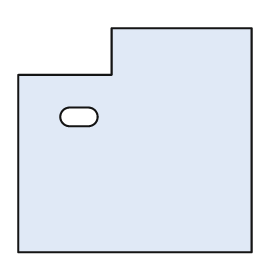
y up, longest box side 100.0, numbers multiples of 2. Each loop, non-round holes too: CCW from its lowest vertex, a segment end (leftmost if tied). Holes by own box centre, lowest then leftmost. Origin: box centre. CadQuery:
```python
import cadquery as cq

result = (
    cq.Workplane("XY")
    .moveTo(-50.0, -48.0)
    .lineTo(50.0, -48.0)
    .lineTo(50.0, 48.0)
    .lineTo(-10.0, 48.0)
    .lineTo(-10.0, 28.0)
    .lineTo(-50.0, 28.0)
    .close()
    .moveTo(-28.0, 6.0)
    .lineTo(-20.0, 6.0)
    .threePointArc((-16.0, 10.0), (-20.0, 14.0))
    .lineTo(-28.0, 14.0)
    .threePointArc((-32.0, 10.0), (-28.0, 6.0))
    .close()
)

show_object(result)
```